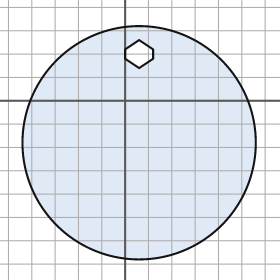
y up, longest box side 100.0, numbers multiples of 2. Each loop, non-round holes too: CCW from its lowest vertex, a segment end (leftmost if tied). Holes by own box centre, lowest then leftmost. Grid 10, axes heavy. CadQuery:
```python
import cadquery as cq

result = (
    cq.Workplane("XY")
    .moveTo(6.0, -18.0)
    .circle(50.0)
    .moveTo(6.0, 14.0)
    .lineTo(12.0, 18.0)
    .lineTo(12.0, 22.0)
    .lineTo(6.0, 26.0)
    .lineTo(0.0, 22.0)
    .lineTo(0.0, 18.0)
    .close()
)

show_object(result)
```